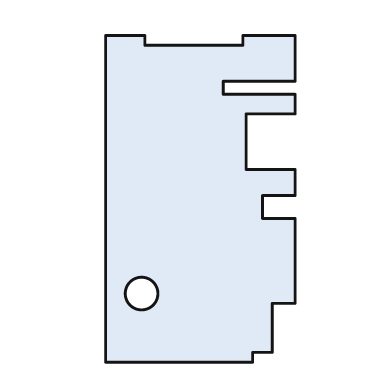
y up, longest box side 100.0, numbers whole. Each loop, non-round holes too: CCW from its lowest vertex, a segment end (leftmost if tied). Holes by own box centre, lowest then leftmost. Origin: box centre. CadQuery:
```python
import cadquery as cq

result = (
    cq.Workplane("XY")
    .moveTo(-29.0, -50.0)
    .lineTo(16.0, -50.0)
    .lineTo(16.0, -47.0)
    .lineTo(22.0, -47.0)
    .lineTo(22.0, -32.0)
    .lineTo(29.0, -32.0)
    .lineTo(29.0, -6.0)
    .lineTo(19.0, -6.0)
    .lineTo(19.0, 1.0)
    .lineTo(29.0, 1.0)
    .lineTo(29.0, 9.0)
    .lineTo(14.0, 9.0)
    .lineTo(14.0, 26.0)
    .lineTo(29.0, 26.0)
    .lineTo(29.0, 32.0)
    .lineTo(7.0, 32.0)
    .lineTo(7.0, 36.0)
    .lineTo(29.0, 36.0)
    .lineTo(29.0, 50.0)
    .lineTo(13.0, 50.0)
    .lineTo(13.0, 47.0)
    .lineTo(-17.0, 47.0)
    .lineTo(-17.0, 50.0)
    .lineTo(-29.0, 50.0)
    .close()
    .moveTo(-18.0, -29.0)
    .circle(5.0)
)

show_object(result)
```